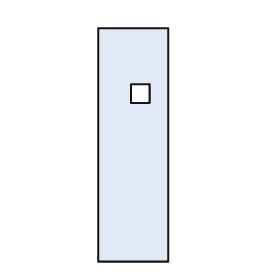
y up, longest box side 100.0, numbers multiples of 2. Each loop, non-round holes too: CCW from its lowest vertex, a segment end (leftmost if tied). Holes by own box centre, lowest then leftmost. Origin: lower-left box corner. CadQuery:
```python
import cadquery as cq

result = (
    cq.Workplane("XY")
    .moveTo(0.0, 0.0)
    .lineTo(30.0, 0.0)
    .lineTo(30.0, 100.0)
    .lineTo(0.0, 100.0)
    .close()
    .moveTo(14.0, 68.0)
    .lineTo(22.0, 68.0)
    .lineTo(22.0, 76.0)
    .lineTo(14.0, 76.0)
    .close()
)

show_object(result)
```